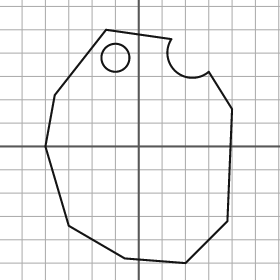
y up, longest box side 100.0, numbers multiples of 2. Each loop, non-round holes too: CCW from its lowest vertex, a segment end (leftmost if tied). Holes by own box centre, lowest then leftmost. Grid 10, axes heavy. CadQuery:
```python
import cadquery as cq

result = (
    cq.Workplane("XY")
    .moveTo(20.0, -50.0)
    .lineTo(38.0, -32.0)
    .lineTo(40.0, 16.0)
    .lineTo(30.0, 32.0)
    .threePointArc((16.0, 32.0), (14.0, 46.0))
    .lineTo(-14.0, 50.0)
    .lineTo(-36.0, 22.0)
    .lineTo(-40.0, 0.0)
    .lineTo(-30.0, -34.0)
    .lineTo(-6.0, -48.0)
    .close()
    .moveTo(-10.0, 38.0)
    .circle(6.0)
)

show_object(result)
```